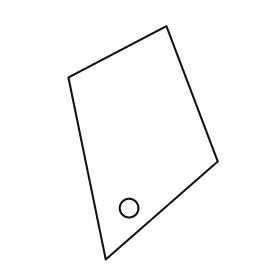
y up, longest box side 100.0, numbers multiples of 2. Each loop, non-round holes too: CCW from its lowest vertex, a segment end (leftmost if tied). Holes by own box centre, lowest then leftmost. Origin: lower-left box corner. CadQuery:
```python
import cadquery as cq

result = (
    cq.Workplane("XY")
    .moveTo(16.0, 0.0)
    .lineTo(64.0, 42.0)
    .lineTo(42.0, 100.0)
    .lineTo(0.0, 78.0)
    .close()
    .moveTo(26.0, 22.0)
    .circle(4.0)
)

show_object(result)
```